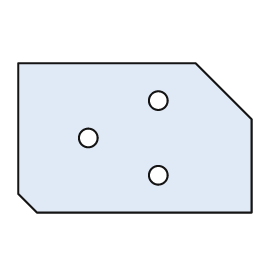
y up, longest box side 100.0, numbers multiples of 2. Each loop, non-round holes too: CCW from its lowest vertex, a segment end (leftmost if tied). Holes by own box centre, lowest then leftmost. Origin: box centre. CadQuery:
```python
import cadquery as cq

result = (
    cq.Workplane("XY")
    .moveTo(-42.0, -32.0)
    .lineTo(50.0, -32.0)
    .lineTo(50.0, 8.0)
    .lineTo(26.0, 32.0)
    .lineTo(-50.0, 32.0)
    .lineTo(-50.0, -24.0)
    .close()
    .moveTo(10.0, -16.0)
    .circle(4.0)
    .moveTo(-20.0, 0.0)
    .circle(4.0)
    .moveTo(10.0, 16.0)
    .circle(4.0)
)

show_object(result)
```